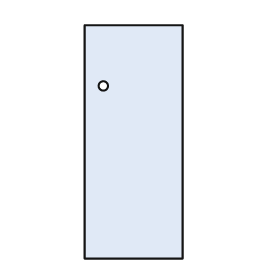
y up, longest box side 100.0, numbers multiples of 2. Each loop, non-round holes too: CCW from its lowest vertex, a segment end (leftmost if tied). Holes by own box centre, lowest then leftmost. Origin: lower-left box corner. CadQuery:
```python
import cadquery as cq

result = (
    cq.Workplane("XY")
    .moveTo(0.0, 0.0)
    .lineTo(42.0, 0.0)
    .lineTo(42.0, 100.0)
    .lineTo(0.0, 100.0)
    .close()
    .moveTo(8.0, 74.0)
    .circle(2.0)
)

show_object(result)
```